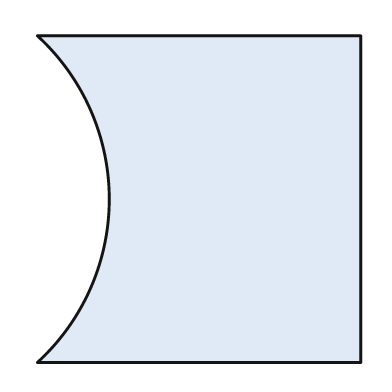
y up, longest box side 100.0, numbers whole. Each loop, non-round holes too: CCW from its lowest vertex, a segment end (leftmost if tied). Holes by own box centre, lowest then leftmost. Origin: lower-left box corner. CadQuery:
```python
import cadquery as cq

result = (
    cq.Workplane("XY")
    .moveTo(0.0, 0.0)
    .lineTo(99.0, 0.0)
    .lineTo(99.0, 100.0)
    .lineTo(0.0, 100.0)
    .threePointArc((22.0, 50.0), (0.0, 0.0))
    .close()
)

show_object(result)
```